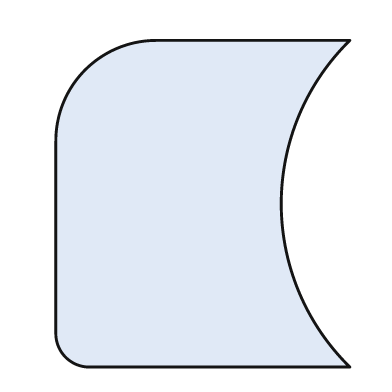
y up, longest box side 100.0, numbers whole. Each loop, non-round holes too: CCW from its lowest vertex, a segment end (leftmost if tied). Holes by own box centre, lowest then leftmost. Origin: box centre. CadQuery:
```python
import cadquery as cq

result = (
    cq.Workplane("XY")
    .moveTo(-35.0, -50.0)
    .lineTo(45.0, -50.0)
    .threePointArc((24.0, 0.0), (45.0, 50.0))
    .lineTo(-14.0, 50.0)
    .threePointArc((-36.0, 41.0), (-45.0, 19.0))
    .lineTo(-45.0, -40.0)
    .threePointArc((-42.0, -47.0), (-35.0, -50.0))
    .close()
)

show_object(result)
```